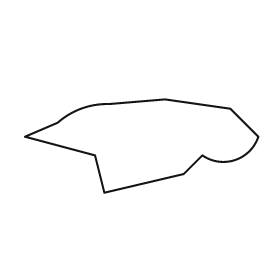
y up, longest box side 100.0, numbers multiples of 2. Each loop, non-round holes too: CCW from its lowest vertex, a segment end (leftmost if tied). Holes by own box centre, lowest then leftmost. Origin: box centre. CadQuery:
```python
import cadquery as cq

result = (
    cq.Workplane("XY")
    .moveTo(-16.0, -20.0)
    .lineTo(18.0, -12.0)
    .lineTo(26.0, -4.0)
    .threePointArc((40.0, -6.0), (50.0, 4.0))
    .lineTo(38.0, 16.0)
    .lineTo(10.0, 20.0)
    .lineTo(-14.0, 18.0)
    .threePointArc((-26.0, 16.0), (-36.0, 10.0))
    .lineTo(-50.0, 4.0)
    .lineTo(-20.0, -4.0)
    .close()
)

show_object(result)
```